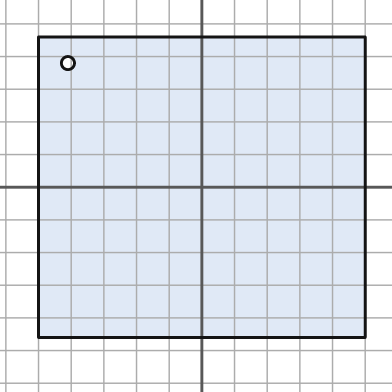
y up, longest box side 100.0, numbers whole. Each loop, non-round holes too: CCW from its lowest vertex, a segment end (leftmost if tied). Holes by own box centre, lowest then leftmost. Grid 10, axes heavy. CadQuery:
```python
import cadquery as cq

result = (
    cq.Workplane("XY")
    .moveTo(-50.0, -46.0)
    .lineTo(50.0, -46.0)
    .lineTo(50.0, 46.0)
    .lineTo(-50.0, 46.0)
    .close()
    .moveTo(-41.0, 38.0)
    .circle(2.0)
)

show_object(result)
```